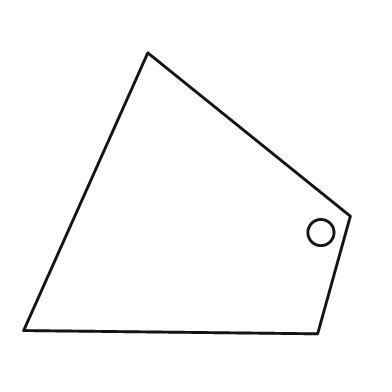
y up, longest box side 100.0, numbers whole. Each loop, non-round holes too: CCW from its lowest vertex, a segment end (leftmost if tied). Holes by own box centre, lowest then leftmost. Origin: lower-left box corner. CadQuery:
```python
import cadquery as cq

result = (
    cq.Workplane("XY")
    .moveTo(90.0, 0.0)
    .lineTo(100.0, 36.0)
    .lineTo(38.0, 86.0)
    .lineTo(0.0, 1.0)
    .close()
    .moveTo(91.0, 31.0)
    .circle(4.0)
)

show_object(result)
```